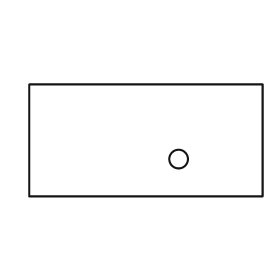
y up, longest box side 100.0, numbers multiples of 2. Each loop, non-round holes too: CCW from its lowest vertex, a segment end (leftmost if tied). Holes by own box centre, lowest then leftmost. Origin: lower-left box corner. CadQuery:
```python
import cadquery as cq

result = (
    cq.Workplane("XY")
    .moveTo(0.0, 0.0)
    .lineTo(100.0, 0.0)
    .lineTo(100.0, 48.0)
    .lineTo(0.0, 48.0)
    .close()
    .moveTo(64.0, 16.0)
    .circle(4.0)
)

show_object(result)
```